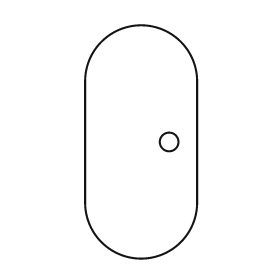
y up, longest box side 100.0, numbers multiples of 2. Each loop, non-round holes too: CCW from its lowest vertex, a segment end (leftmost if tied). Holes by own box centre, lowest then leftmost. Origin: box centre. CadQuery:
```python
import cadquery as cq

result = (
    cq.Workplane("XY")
    .moveTo(-24.0, -26.0)
    .threePointArc((0.0, -50.0), (24.0, -26.0))
    .lineTo(24.0, 26.0)
    .threePointArc((0.0, 50.0), (-24.0, 26.0))
    .close()
    .moveTo(12.0, 0.0)
    .circle(4.0)
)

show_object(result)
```